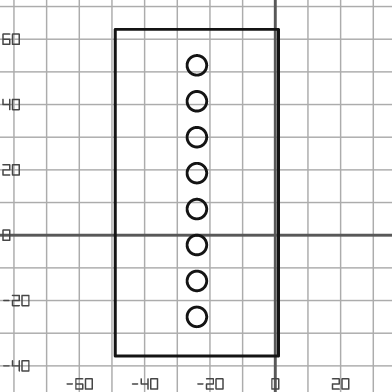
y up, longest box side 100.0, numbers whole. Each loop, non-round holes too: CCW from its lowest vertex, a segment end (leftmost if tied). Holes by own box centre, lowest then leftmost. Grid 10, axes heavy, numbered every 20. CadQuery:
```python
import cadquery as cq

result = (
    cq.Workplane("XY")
    .moveTo(-49.0, -37.0)
    .lineTo(1.0, -37.0)
    .lineTo(1.0, 63.0)
    .lineTo(-49.0, 63.0)
    .close()
    .moveTo(-24.0, -25.0)
    .circle(3.0)
    .moveTo(-24.0, -14.0)
    .circle(3.0)
    .moveTo(-24.0, -3.0)
    .circle(3.0)
    .moveTo(-24.0, 8.0)
    .circle(3.0)
    .moveTo(-24.0, 19.0)
    .circle(3.0)
    .moveTo(-24.0, 30.0)
    .circle(3.0)
    .moveTo(-24.0, 41.0)
    .circle(3.0)
    .moveTo(-24.0, 52.0)
    .circle(3.0)
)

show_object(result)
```